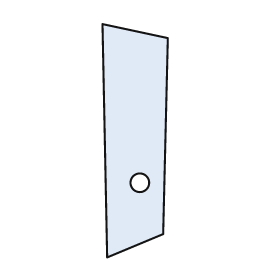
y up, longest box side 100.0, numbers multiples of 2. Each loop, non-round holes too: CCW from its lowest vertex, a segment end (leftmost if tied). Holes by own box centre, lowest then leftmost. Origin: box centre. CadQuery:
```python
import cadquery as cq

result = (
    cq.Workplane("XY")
    .moveTo(-12.0, -50.0)
    .lineTo(12.0, -40.0)
    .lineTo(14.0, 44.0)
    .lineTo(-14.0, 50.0)
    .close()
    .moveTo(2.0, -18.0)
    .circle(4.0)
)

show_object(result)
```